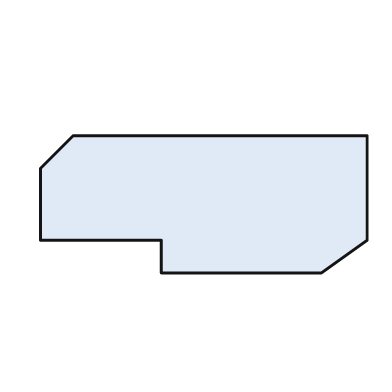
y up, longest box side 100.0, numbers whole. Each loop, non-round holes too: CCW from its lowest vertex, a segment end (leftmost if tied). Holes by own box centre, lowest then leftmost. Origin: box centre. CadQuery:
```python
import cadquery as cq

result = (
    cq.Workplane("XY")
    .moveTo(-13.0, -21.0)
    .lineTo(36.0, -21.0)
    .lineTo(50.0, -11.0)
    .lineTo(50.0, 21.0)
    .lineTo(-40.0, 21.0)
    .lineTo(-50.0, 11.0)
    .lineTo(-50.0, -11.0)
    .lineTo(-13.0, -11.0)
    .close()
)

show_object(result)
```